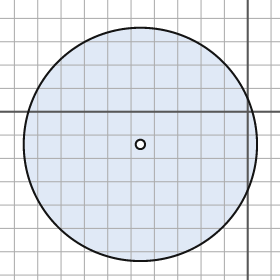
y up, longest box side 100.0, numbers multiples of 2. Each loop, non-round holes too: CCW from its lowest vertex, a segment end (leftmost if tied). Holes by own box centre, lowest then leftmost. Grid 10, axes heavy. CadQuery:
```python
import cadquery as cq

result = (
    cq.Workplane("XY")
    .moveTo(-46.0, -14.0)
    .circle(50.0)
    .moveTo(-46.0, -14.0)
    .circle(2.0)
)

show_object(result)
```